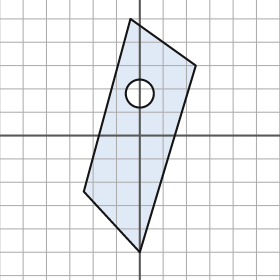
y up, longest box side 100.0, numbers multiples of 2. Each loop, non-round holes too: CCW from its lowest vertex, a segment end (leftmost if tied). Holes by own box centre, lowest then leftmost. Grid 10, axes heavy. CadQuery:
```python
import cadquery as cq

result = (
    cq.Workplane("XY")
    .moveTo(0.0, -50.0)
    .lineTo(24.0, 30.0)
    .lineTo(-4.0, 50.0)
    .lineTo(-24.0, -24.0)
    .close()
    .moveTo(0.0, 18.0)
    .circle(6.0)
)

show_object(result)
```